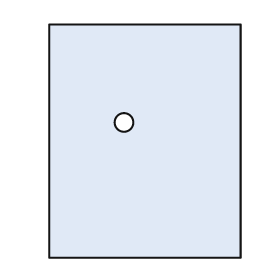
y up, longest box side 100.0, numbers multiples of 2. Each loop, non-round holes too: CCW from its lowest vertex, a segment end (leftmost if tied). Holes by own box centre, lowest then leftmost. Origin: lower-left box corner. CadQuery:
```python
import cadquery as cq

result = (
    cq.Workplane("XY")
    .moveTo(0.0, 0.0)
    .lineTo(82.0, 0.0)
    .lineTo(82.0, 100.0)
    .lineTo(0.0, 100.0)
    .close()
    .moveTo(32.0, 58.0)
    .circle(4.0)
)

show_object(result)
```